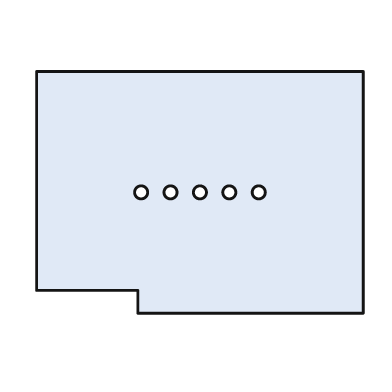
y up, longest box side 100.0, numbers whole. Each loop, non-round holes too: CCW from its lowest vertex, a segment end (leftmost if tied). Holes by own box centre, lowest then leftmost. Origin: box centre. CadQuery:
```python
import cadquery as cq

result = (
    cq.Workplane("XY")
    .moveTo(-19.0, -37.0)
    .lineTo(50.0, -37.0)
    .lineTo(50.0, 37.0)
    .lineTo(-50.0, 37.0)
    .lineTo(-50.0, -30.0)
    .lineTo(-19.0, -30.0)
    .close()
    .moveTo(-18.0, 0.0)
    .circle(2.0)
    .moveTo(-9.0, 0.0)
    .circle(2.0)
    .moveTo(0.0, 0.0)
    .circle(2.0)
    .moveTo(9.0, 0.0)
    .circle(2.0)
    .moveTo(18.0, 0.0)
    .circle(2.0)
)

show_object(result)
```